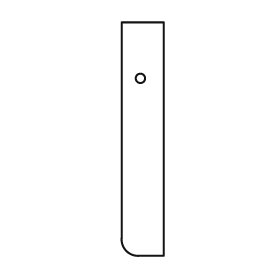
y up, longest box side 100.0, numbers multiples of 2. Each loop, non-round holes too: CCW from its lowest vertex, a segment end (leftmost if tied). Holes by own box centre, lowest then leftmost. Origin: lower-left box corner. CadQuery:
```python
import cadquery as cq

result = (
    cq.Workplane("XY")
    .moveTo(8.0, 0.0)
    .lineTo(18.0, 0.0)
    .lineTo(18.0, 100.0)
    .lineTo(0.0, 100.0)
    .lineTo(0.0, 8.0)
    .threePointArc((2.0, 2.0), (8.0, 0.0))
    .close()
    .moveTo(8.0, 76.0)
    .circle(2.0)
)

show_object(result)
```